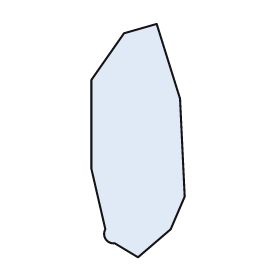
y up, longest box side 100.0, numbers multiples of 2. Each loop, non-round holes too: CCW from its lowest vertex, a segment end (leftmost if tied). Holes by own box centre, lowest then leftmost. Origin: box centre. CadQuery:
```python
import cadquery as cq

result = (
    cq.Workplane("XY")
    .moveTo(0.0, -50.0)
    .lineTo(14.0, -38.0)
    .lineTo(20.0, -24.0)
    .lineTo(18.0, 18.0)
    .lineTo(8.0, 50.0)
    .lineTo(-6.0, 46.0)
    .lineTo(-20.0, 26.0)
    .lineTo(-20.0, -12.0)
    .lineTo(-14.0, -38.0)
    .threePointArc((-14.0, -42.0), (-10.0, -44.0))
    .close()
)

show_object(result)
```